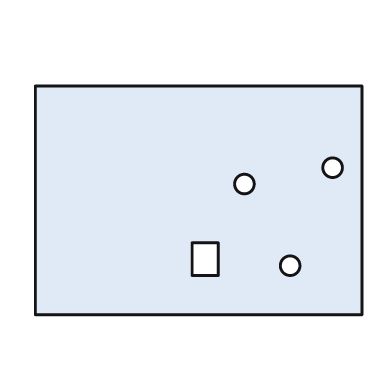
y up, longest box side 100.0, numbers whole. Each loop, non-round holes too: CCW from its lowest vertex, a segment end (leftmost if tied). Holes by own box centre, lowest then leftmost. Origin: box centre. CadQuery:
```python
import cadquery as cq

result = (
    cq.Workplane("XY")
    .moveTo(-50.0, -35.0)
    .lineTo(50.0, -35.0)
    .lineTo(50.0, 35.0)
    .lineTo(-50.0, 35.0)
    .close()
    .moveTo(28.0, -20.0)
    .circle(3.0)
    .moveTo(-2.0, -23.0)
    .lineTo(6.0, -23.0)
    .lineTo(6.0, -13.0)
    .lineTo(-2.0, -13.0)
    .close()
    .moveTo(14.0, 5.0)
    .circle(3.0)
    .moveTo(41.0, 10.0)
    .circle(3.0)
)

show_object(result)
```